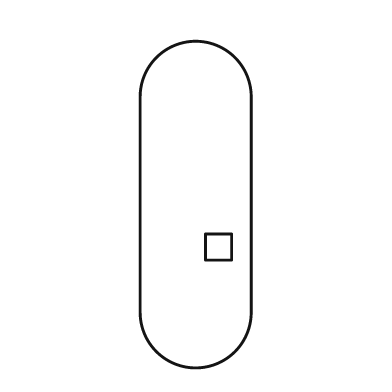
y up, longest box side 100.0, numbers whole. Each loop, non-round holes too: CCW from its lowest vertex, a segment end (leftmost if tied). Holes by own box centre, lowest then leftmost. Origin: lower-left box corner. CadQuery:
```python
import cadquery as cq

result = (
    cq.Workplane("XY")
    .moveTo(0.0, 17.0)
    .threePointArc((17.0, 0.0), (34.0, 17.0))
    .lineTo(34.0, 83.0)
    .threePointArc((17.0, 100.0), (0.0, 83.0))
    .close()
    .moveTo(20.0, 33.0)
    .lineTo(28.0, 33.0)
    .lineTo(28.0, 41.0)
    .lineTo(20.0, 41.0)
    .close()
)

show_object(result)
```